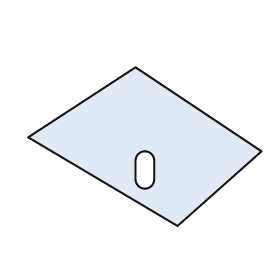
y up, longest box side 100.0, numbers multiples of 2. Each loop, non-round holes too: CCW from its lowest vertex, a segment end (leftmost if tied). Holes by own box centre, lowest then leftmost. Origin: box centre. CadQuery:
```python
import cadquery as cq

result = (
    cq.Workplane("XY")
    .moveTo(14.0, -34.0)
    .lineTo(50.0, -2.0)
    .lineTo(-4.0, 34.0)
    .lineTo(-50.0, 4.0)
    .close()
    .moveTo(-4.0, -14.0)
    .threePointArc((0.0, -18.0), (4.0, -14.0))
    .lineTo(4.0, -6.0)
    .threePointArc((0.0, -2.0), (-4.0, -6.0))
    .close()
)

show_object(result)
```